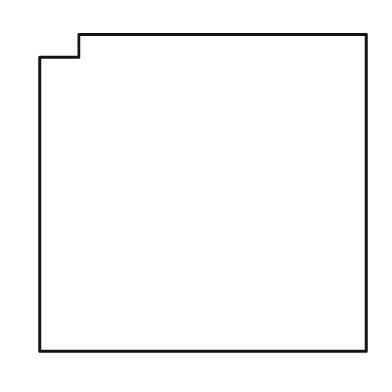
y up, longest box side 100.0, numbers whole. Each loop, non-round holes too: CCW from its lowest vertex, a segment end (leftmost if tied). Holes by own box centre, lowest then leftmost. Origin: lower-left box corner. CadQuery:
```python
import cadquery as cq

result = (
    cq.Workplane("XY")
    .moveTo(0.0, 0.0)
    .lineTo(100.0, 0.0)
    .lineTo(100.0, 97.0)
    .lineTo(12.0, 97.0)
    .lineTo(12.0, 90.0)
    .lineTo(0.0, 90.0)
    .close()
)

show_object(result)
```